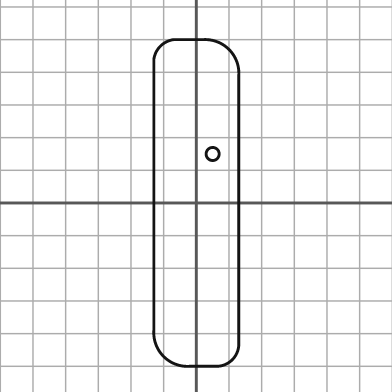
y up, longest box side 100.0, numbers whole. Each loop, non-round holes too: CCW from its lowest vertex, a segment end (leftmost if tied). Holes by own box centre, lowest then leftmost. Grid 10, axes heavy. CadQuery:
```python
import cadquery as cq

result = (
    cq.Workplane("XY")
    .moveTo(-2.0, -50.0)
    .lineTo(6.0, -50.0)
    .threePointArc((11.0, -48.0), (13.0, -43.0))
    .lineTo(13.0, 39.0)
    .threePointArc((10.0, 47.0), (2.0, 50.0))
    .lineTo(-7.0, 50.0)
    .threePointArc((-11.0, 48.0), (-13.0, 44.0))
    .lineTo(-13.0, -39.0)
    .threePointArc((-10.0, -47.0), (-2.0, -50.0))
    .close()
    .moveTo(5.0, 15.0)
    .circle(2.0)
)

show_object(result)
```